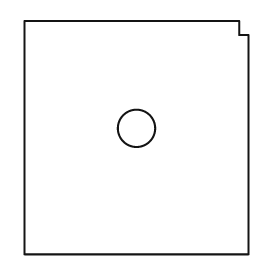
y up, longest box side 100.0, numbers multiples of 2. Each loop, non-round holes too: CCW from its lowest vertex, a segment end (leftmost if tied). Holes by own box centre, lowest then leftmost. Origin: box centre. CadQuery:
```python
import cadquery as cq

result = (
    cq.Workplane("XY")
    .moveTo(-48.0, -50.0)
    .lineTo(48.0, -50.0)
    .lineTo(48.0, 44.0)
    .lineTo(44.0, 44.0)
    .lineTo(44.0, 50.0)
    .lineTo(-48.0, 50.0)
    .close()
    .moveTo(0.0, 4.0)
    .circle(8.0)
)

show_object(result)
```